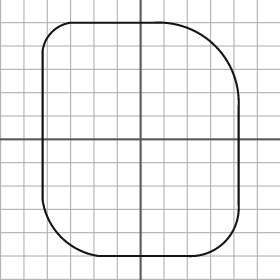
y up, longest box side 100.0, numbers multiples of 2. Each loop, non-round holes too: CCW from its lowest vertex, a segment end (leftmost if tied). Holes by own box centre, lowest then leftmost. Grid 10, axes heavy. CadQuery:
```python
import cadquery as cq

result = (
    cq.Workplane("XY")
    .moveTo(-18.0, -50.0)
    .lineTo(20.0, -50.0)
    .threePointArc((36.0, -44.0), (42.0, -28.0))
    .lineTo(42.0, 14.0)
    .threePointArc((32.0, 40.0), (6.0, 50.0))
    .lineTo(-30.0, 50.0)
    .threePointArc((-38.0, 46.0), (-42.0, 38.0))
    .lineTo(-42.0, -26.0)
    .threePointArc((-34.0, -42.0), (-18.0, -50.0))
    .close()
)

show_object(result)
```